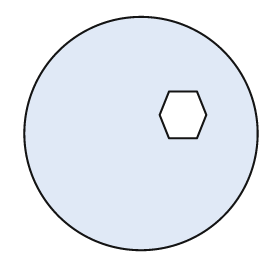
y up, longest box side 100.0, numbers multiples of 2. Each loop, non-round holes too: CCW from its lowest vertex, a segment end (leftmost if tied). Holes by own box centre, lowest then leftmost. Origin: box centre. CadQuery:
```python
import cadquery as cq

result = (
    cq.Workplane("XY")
    .moveTo(0.0, 0.0)
    .circle(50.0)
    .moveTo(12.0, -2.0)
    .lineTo(24.0, -2.0)
    .lineTo(28.0, 8.0)
    .lineTo(24.0, 18.0)
    .lineTo(12.0, 18.0)
    .lineTo(8.0, 8.0)
    .close()
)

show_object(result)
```